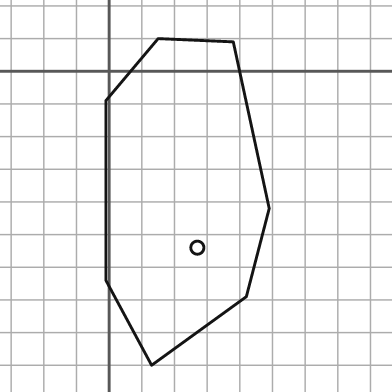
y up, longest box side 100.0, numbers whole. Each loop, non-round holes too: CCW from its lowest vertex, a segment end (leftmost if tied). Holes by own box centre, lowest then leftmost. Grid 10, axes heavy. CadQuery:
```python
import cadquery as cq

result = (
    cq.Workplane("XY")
    .moveTo(13.0, -90.0)
    .lineTo(42.0, -69.0)
    .lineTo(49.0, -42.0)
    .lineTo(38.0, 9.0)
    .lineTo(15.0, 10.0)
    .lineTo(-1.0, -9.0)
    .lineTo(-1.0, -64.0)
    .close()
    .moveTo(27.0, -54.0)
    .circle(2.0)
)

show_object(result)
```